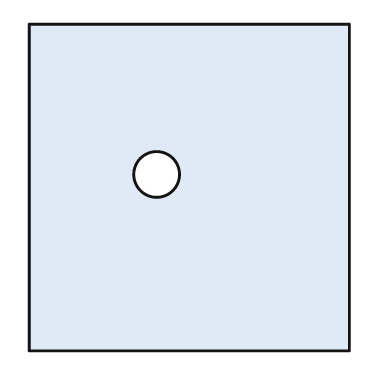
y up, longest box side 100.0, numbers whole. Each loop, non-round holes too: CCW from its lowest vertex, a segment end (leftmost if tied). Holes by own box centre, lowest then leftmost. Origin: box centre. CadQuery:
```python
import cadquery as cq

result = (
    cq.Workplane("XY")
    .moveTo(-49.0, -50.0)
    .lineTo(49.0, -50.0)
    .lineTo(49.0, 50.0)
    .lineTo(-49.0, 50.0)
    .close()
    .moveTo(-10.0, 4.0)
    .circle(7.0)
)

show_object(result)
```